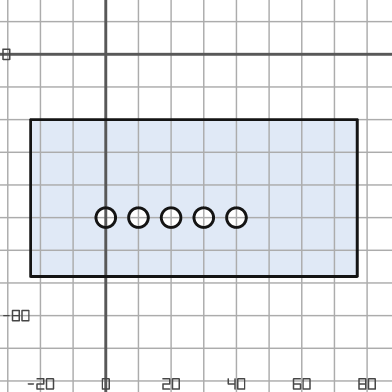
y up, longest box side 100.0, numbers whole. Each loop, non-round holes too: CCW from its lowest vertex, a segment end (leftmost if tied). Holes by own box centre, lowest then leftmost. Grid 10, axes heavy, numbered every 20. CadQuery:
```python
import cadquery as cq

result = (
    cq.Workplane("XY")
    .moveTo(-23.0, -68.0)
    .lineTo(77.0, -68.0)
    .lineTo(77.0, -20.0)
    .lineTo(-23.0, -20.0)
    .close()
    .moveTo(0.0, -50.0)
    .circle(3.0)
    .moveTo(10.0, -50.0)
    .circle(3.0)
    .moveTo(20.0, -50.0)
    .circle(3.0)
    .moveTo(30.0, -50.0)
    .circle(3.0)
    .moveTo(40.0, -50.0)
    .circle(3.0)
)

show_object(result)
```